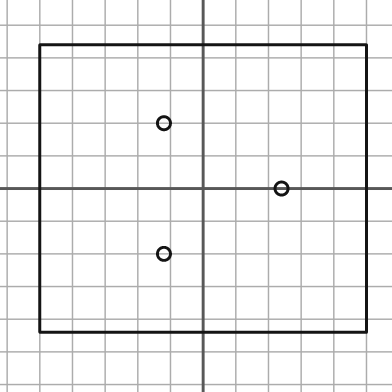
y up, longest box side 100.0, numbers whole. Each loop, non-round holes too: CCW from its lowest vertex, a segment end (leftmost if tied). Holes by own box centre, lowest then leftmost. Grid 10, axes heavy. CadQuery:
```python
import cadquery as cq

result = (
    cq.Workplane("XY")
    .moveTo(-50.0, -44.0)
    .lineTo(50.0, -44.0)
    .lineTo(50.0, 44.0)
    .lineTo(-50.0, 44.0)
    .close()
    .moveTo(-12.0, -20.0)
    .circle(2.0)
    .moveTo(24.0, 0.0)
    .circle(2.0)
    .moveTo(-12.0, 20.0)
    .circle(2.0)
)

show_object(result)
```